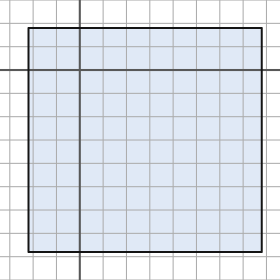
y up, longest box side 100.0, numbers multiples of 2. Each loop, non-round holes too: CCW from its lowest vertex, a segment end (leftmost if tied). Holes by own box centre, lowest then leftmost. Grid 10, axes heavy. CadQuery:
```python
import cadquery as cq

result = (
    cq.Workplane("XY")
    .moveTo(-22.0, -78.0)
    .lineTo(78.0, -78.0)
    .lineTo(78.0, 18.0)
    .lineTo(-22.0, 18.0)
    .close()
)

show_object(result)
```